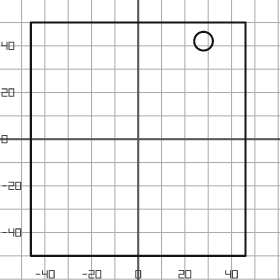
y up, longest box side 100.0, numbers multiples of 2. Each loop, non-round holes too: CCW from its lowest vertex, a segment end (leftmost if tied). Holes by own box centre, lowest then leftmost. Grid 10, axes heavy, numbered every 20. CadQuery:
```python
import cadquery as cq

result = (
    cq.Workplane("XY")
    .moveTo(-46.0, -50.0)
    .lineTo(46.0, -50.0)
    .lineTo(46.0, 50.0)
    .lineTo(-46.0, 50.0)
    .close()
    .moveTo(28.0, 42.0)
    .circle(4.0)
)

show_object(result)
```